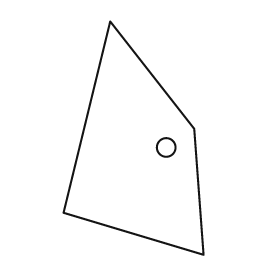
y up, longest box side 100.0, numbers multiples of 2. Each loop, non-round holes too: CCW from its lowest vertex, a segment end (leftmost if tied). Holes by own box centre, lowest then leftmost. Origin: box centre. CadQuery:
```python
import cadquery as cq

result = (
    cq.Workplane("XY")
    .moveTo(30.0, -50.0)
    .lineTo(26.0, 4.0)
    .lineTo(-10.0, 50.0)
    .lineTo(-30.0, -32.0)
    .close()
    .moveTo(14.0, -4.0)
    .circle(4.0)
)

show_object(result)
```